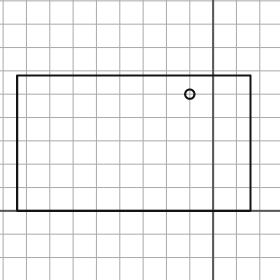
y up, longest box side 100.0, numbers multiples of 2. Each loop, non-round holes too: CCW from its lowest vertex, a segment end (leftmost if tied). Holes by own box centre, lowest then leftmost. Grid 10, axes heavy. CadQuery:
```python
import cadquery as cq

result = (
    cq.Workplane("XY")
    .moveTo(-84.0, 0.0)
    .lineTo(16.0, 0.0)
    .lineTo(16.0, 58.0)
    .lineTo(-84.0, 58.0)
    .close()
    .moveTo(-10.0, 50.0)
    .circle(2.0)
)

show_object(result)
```